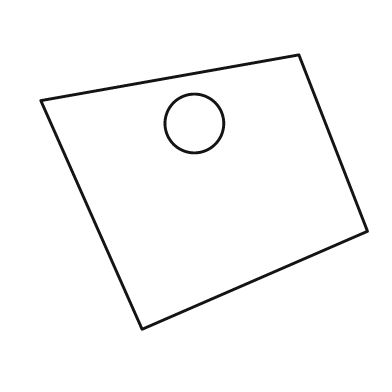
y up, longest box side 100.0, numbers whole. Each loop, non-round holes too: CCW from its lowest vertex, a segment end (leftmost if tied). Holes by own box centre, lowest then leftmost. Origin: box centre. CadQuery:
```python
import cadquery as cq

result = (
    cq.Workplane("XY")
    .moveTo(-19.0, -42.0)
    .lineTo(50.0, -12.0)
    .lineTo(29.0, 42.0)
    .lineTo(-50.0, 28.0)
    .close()
    .moveTo(-3.0, 21.0)
    .circle(9.0)
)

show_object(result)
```